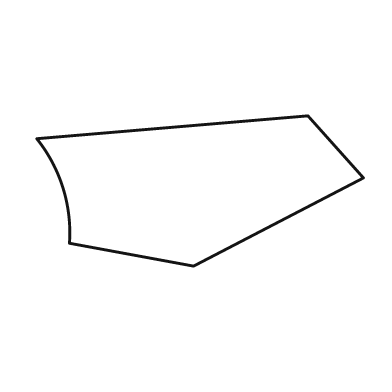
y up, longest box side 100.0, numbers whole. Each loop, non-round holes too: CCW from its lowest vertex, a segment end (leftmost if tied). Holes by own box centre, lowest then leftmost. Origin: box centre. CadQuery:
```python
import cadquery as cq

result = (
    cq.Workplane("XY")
    .moveTo(-2.0, -23.0)
    .lineTo(50.0, 4.0)
    .lineTo(33.0, 23.0)
    .lineTo(-50.0, 16.0)
    .threePointArc((-42.0, 1.0), (-40.0, -16.0))
    .close()
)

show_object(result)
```